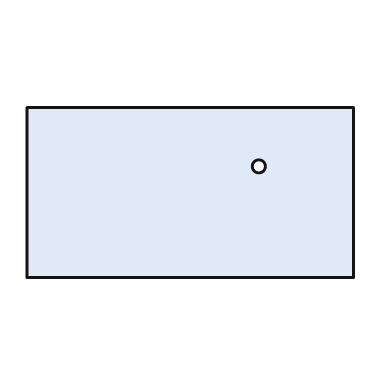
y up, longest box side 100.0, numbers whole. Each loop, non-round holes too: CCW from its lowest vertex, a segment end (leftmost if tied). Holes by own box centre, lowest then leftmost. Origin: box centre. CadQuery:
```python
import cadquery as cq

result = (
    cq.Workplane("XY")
    .moveTo(-50.0, -26.0)
    .lineTo(50.0, -26.0)
    .lineTo(50.0, 26.0)
    .lineTo(-50.0, 26.0)
    .close()
    .moveTo(21.0, 8.0)
    .circle(2.0)
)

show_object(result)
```